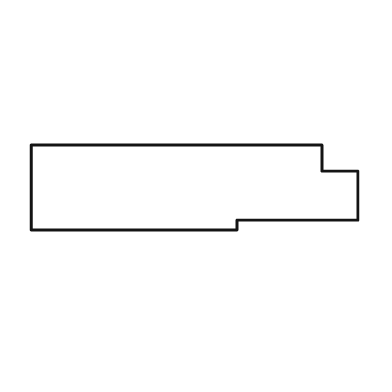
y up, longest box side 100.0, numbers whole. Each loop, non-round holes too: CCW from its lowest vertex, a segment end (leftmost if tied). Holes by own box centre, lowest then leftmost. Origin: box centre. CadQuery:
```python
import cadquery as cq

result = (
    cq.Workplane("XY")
    .moveTo(-50.0, -13.0)
    .lineTo(13.0, -13.0)
    .lineTo(13.0, -10.0)
    .lineTo(50.0, -10.0)
    .lineTo(50.0, 5.0)
    .lineTo(39.0, 5.0)
    .lineTo(39.0, 13.0)
    .lineTo(-50.0, 13.0)
    .close()
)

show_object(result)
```